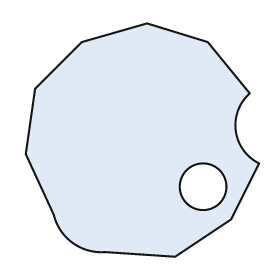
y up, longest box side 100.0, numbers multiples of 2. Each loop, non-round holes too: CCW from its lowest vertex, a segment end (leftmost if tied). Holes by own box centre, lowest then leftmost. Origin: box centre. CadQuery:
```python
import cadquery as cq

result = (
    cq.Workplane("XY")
    .moveTo(14.0, -50.0)
    .lineTo(38.0, -34.0)
    .lineTo(50.0, -10.0)
    .threePointArc((40.0, 4.0), (46.0, 20.0))
    .lineTo(28.0, 42.0)
    .lineTo(2.0, 50.0)
    .lineTo(-26.0, 42.0)
    .lineTo(-46.0, 22.0)
    .lineTo(-50.0, -6.0)
    .lineTo(-38.0, -32.0)
    .threePointArc((-30.0, -44.0), (-16.0, -48.0))
    .close()
    .moveTo(26.0, -20.0)
    .circle(10.0)
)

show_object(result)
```